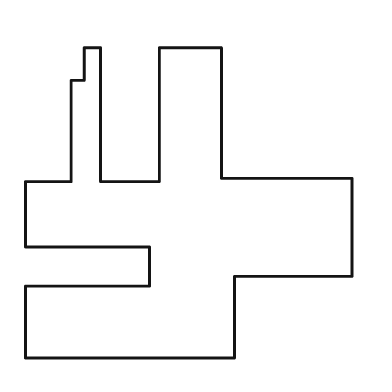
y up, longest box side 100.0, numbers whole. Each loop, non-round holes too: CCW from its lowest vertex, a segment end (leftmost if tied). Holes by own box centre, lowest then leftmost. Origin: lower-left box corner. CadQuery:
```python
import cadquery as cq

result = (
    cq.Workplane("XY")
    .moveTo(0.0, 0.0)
    .lineTo(64.0, 0.0)
    .lineTo(64.0, 25.0)
    .lineTo(100.0, 25.0)
    .lineTo(100.0, 55.0)
    .lineTo(60.0, 55.0)
    .lineTo(60.0, 95.0)
    .lineTo(41.0, 95.0)
    .lineTo(41.0, 54.0)
    .lineTo(23.0, 54.0)
    .lineTo(23.0, 95.0)
    .lineTo(18.0, 95.0)
    .lineTo(18.0, 85.0)
    .lineTo(14.0, 85.0)
    .lineTo(14.0, 54.0)
    .lineTo(0.0, 54.0)
    .lineTo(0.0, 34.0)
    .lineTo(38.0, 34.0)
    .lineTo(38.0, 22.0)
    .lineTo(0.0, 22.0)
    .close()
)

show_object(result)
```